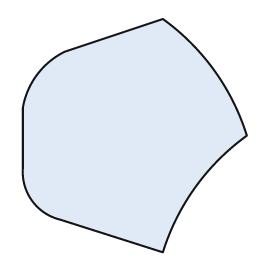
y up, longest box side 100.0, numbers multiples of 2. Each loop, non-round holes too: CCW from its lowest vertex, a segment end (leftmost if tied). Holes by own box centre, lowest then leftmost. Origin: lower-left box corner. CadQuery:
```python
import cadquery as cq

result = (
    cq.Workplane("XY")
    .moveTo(60.0, 0.0)
    .threePointArc((74.0, 28.0), (96.0, 50.0))
    .threePointArc((82.0, 78.0), (60.0, 100.0))
    .lineTo(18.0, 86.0)
    .threePointArc((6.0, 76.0), (0.0, 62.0))
    .lineTo(0.0, 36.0)
    .threePointArc((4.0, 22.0), (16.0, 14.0))
    .close()
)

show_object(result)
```